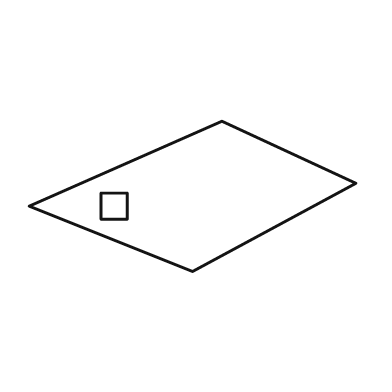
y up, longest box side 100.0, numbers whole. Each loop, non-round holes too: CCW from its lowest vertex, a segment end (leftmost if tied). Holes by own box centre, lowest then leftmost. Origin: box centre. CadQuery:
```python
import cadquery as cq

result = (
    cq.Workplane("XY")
    .moveTo(0.0, -23.0)
    .lineTo(50.0, 4.0)
    .lineTo(9.0, 23.0)
    .lineTo(-50.0, -3.0)
    .close()
    .moveTo(-28.0, -7.0)
    .lineTo(-20.0, -7.0)
    .lineTo(-20.0, 1.0)
    .lineTo(-28.0, 1.0)
    .close()
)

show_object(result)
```